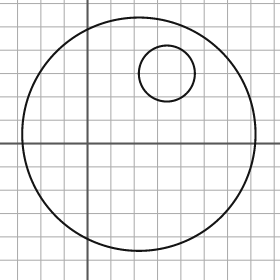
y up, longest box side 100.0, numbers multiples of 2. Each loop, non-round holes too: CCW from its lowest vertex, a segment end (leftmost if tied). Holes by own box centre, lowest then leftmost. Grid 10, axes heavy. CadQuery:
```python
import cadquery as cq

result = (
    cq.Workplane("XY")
    .moveTo(22.0, 4.0)
    .circle(50.0)
    .moveTo(34.0, 30.0)
    .circle(12.0)
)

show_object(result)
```